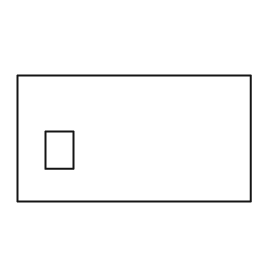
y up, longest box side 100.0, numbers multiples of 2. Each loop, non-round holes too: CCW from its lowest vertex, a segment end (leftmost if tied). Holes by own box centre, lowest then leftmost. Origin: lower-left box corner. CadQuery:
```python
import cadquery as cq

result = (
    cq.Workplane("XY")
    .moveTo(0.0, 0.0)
    .lineTo(100.0, 0.0)
    .lineTo(100.0, 54.0)
    .lineTo(0.0, 54.0)
    .close()
    .moveTo(12.0, 14.0)
    .lineTo(24.0, 14.0)
    .lineTo(24.0, 30.0)
    .lineTo(12.0, 30.0)
    .close()
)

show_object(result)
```